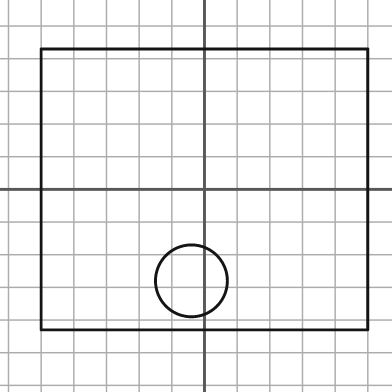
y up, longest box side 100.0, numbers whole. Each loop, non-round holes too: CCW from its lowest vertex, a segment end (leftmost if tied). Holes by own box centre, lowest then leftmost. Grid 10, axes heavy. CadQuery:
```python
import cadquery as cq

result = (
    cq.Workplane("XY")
    .moveTo(-50.0, -43.0)
    .lineTo(50.0, -43.0)
    .lineTo(50.0, 43.0)
    .lineTo(-50.0, 43.0)
    .close()
    .moveTo(-4.0, -28.0)
    .circle(11.0)
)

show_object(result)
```